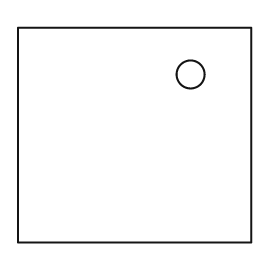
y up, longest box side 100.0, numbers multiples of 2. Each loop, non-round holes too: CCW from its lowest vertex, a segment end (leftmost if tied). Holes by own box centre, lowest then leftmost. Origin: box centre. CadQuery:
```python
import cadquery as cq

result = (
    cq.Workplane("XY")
    .moveTo(-50.0, -46.0)
    .lineTo(50.0, -46.0)
    .lineTo(50.0, 46.0)
    .lineTo(-50.0, 46.0)
    .close()
    .moveTo(24.0, 26.0)
    .circle(6.0)
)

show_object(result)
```